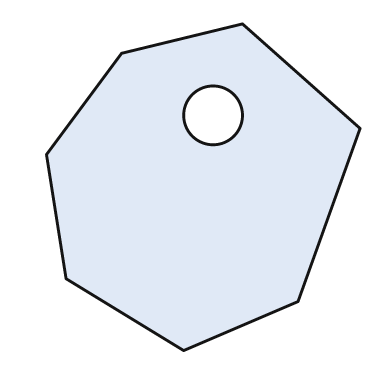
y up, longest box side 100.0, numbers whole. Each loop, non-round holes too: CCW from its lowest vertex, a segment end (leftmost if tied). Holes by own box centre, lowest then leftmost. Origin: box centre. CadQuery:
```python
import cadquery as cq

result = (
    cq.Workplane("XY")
    .moveTo(-6.0, -50.0)
    .lineTo(29.0, -35.0)
    .lineTo(48.0, 18.0)
    .lineTo(12.0, 50.0)
    .lineTo(-25.0, 41.0)
    .lineTo(-48.0, 10.0)
    .lineTo(-42.0, -28.0)
    .close()
    .moveTo(3.0, 22.0)
    .circle(9.0)
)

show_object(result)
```